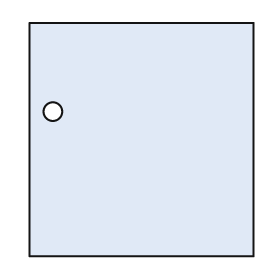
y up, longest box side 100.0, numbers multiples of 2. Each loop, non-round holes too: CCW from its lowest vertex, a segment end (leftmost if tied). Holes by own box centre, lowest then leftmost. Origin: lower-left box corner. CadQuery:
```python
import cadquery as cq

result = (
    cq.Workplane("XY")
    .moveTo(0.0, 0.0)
    .lineTo(96.0, 0.0)
    .lineTo(96.0, 100.0)
    .lineTo(0.0, 100.0)
    .close()
    .moveTo(10.0, 62.0)
    .circle(4.0)
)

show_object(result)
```